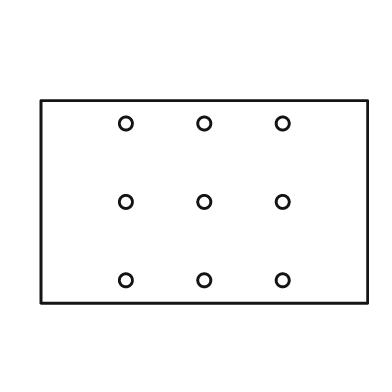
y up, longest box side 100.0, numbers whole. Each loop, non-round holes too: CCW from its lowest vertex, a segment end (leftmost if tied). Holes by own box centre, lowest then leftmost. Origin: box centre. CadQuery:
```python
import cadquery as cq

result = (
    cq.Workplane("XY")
    .moveTo(-50.0, -31.0)
    .lineTo(50.0, -31.0)
    .lineTo(50.0, 31.0)
    .lineTo(-50.0, 31.0)
    .close()
    .moveTo(-24.0, -24.0)
    .circle(2.0)
    .moveTo(0.0, -24.0)
    .circle(2.0)
    .moveTo(24.0, -24.0)
    .circle(2.0)
    .moveTo(-24.0, 0.0)
    .circle(2.0)
    .moveTo(0.0, 0.0)
    .circle(2.0)
    .moveTo(24.0, 0.0)
    .circle(2.0)
    .moveTo(-24.0, 24.0)
    .circle(2.0)
    .moveTo(0.0, 24.0)
    .circle(2.0)
    .moveTo(24.0, 24.0)
    .circle(2.0)
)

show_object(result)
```